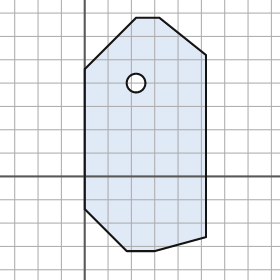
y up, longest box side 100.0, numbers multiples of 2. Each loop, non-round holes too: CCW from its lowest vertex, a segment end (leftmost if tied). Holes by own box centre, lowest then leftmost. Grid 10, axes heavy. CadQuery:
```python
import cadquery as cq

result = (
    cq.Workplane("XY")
    .moveTo(18.0, -32.0)
    .lineTo(30.0, -32.0)
    .lineTo(52.0, -26.0)
    .lineTo(52.0, 52.0)
    .lineTo(32.0, 68.0)
    .lineTo(22.0, 68.0)
    .lineTo(0.0, 46.0)
    .lineTo(0.0, -14.0)
    .close()
    .moveTo(22.0, 40.0)
    .circle(4.0)
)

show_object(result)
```